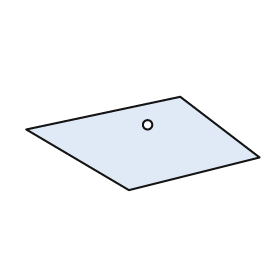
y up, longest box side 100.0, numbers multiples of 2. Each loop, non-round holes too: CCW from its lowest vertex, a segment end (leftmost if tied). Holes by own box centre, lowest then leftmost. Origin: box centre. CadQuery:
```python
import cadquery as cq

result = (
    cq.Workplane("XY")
    .moveTo(-6.0, -20.0)
    .lineTo(50.0, -6.0)
    .lineTo(16.0, 20.0)
    .lineTo(-50.0, 6.0)
    .close()
    .moveTo(2.0, 8.0)
    .circle(2.0)
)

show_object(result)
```